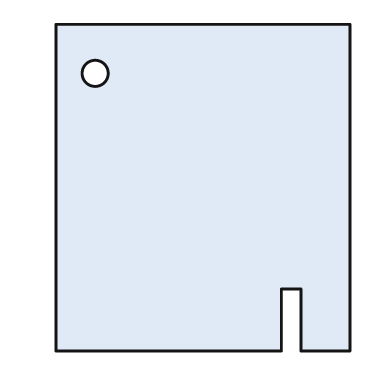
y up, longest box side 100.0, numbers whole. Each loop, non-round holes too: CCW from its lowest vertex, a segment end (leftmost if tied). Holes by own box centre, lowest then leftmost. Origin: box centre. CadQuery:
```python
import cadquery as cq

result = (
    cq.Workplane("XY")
    .moveTo(-45.0, -50.0)
    .lineTo(24.0, -50.0)
    .lineTo(24.0, -31.0)
    .lineTo(30.0, -31.0)
    .lineTo(30.0, -50.0)
    .lineTo(45.0, -50.0)
    .lineTo(45.0, 50.0)
    .lineTo(-45.0, 50.0)
    .close()
    .moveTo(-33.0, 35.0)
    .circle(4.0)
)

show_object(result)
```